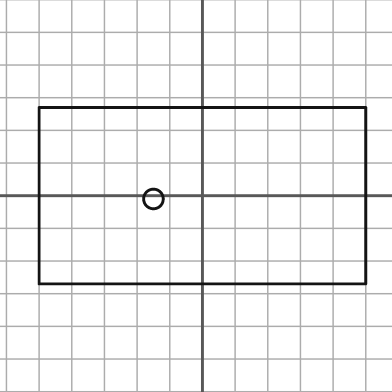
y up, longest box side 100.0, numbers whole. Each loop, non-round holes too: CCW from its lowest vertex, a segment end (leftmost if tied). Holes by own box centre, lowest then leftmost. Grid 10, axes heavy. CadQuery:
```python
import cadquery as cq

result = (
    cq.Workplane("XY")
    .moveTo(-50.0, -27.0)
    .lineTo(50.0, -27.0)
    .lineTo(50.0, 27.0)
    .lineTo(-50.0, 27.0)
    .close()
    .moveTo(-15.0, -1.0)
    .circle(3.0)
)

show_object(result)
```